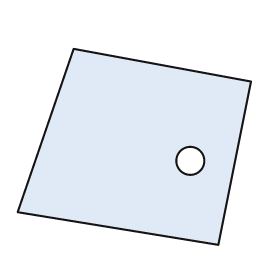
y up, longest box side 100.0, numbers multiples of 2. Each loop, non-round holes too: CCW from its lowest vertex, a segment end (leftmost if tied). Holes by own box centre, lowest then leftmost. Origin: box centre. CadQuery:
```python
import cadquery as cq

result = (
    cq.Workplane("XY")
    .moveTo(36.0, -42.0)
    .lineTo(50.0, 28.0)
    .lineTo(-26.0, 42.0)
    .lineTo(-50.0, -28.0)
    .close()
    .moveTo(24.0, -6.0)
    .circle(6.0)
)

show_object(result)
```